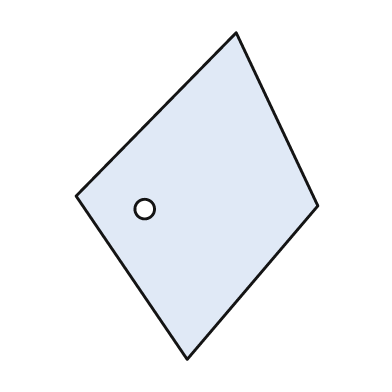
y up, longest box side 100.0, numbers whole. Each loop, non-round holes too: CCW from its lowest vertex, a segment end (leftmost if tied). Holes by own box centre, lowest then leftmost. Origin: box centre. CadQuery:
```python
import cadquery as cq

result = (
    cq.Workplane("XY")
    .moveTo(-3.0, -50.0)
    .lineTo(37.0, -3.0)
    .lineTo(12.0, 50.0)
    .lineTo(-37.0, 0.0)
    .close()
    .moveTo(-16.0, -4.0)
    .circle(3.0)
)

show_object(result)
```